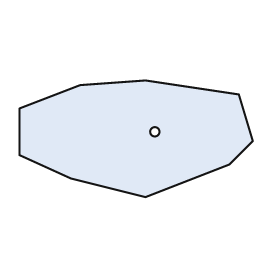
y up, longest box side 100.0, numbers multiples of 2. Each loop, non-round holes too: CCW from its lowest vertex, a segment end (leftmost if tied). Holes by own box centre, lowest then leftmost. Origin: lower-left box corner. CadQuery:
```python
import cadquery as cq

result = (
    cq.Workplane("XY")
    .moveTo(54.0, 0.0)
    .lineTo(90.0, 14.0)
    .lineTo(100.0, 24.0)
    .lineTo(94.0, 44.0)
    .lineTo(54.0, 50.0)
    .lineTo(26.0, 48.0)
    .lineTo(0.0, 38.0)
    .lineTo(0.0, 18.0)
    .lineTo(22.0, 8.0)
    .close()
    .moveTo(58.0, 28.0)
    .circle(2.0)
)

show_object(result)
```